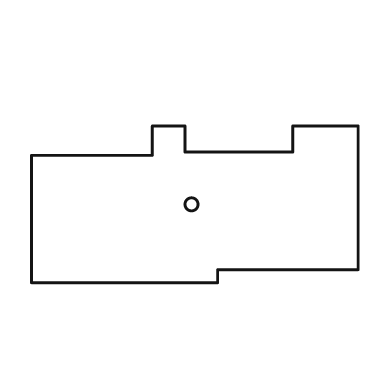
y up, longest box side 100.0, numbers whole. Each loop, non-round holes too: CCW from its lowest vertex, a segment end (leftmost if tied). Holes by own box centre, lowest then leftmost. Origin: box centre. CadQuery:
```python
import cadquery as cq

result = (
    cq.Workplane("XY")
    .moveTo(-50.0, -24.0)
    .lineTo(7.0, -24.0)
    .lineTo(7.0, -20.0)
    .lineTo(50.0, -20.0)
    .lineTo(50.0, 24.0)
    .lineTo(30.0, 24.0)
    .lineTo(30.0, 16.0)
    .lineTo(-3.0, 16.0)
    .lineTo(-3.0, 24.0)
    .lineTo(-13.0, 24.0)
    .lineTo(-13.0, 15.0)
    .lineTo(-50.0, 15.0)
    .close()
    .moveTo(-1.0, 0.0)
    .circle(2.0)
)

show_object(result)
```